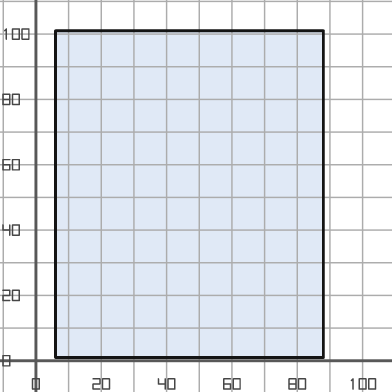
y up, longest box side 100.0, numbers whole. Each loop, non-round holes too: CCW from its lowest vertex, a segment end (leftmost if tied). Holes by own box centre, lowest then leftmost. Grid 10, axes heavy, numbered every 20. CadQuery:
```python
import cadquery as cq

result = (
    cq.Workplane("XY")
    .moveTo(6.0, 1.0)
    .lineTo(88.0, 1.0)
    .lineTo(88.0, 101.0)
    .lineTo(6.0, 101.0)
    .close()
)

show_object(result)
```